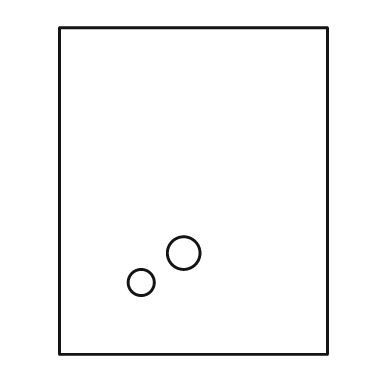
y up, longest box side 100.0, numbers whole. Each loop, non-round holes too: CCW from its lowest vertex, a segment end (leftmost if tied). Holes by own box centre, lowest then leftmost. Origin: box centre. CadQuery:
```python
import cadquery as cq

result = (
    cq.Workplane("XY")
    .moveTo(-41.0, -50.0)
    .lineTo(41.0, -50.0)
    .lineTo(41.0, 50.0)
    .lineTo(-41.0, 50.0)
    .close()
    .moveTo(-16.0, -28.0)
    .circle(4.0)
    .moveTo(-3.0, -19.0)
    .circle(5.0)
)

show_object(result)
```